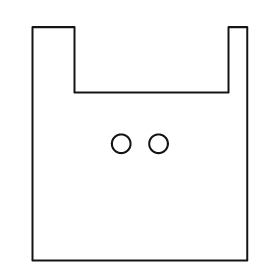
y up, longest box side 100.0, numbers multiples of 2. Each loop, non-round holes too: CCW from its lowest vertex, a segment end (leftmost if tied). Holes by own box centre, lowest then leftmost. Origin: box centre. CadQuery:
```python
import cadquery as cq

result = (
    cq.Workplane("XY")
    .moveTo(-46.0, -50.0)
    .lineTo(46.0, -50.0)
    .lineTo(46.0, 50.0)
    .lineTo(38.0, 50.0)
    .lineTo(38.0, 22.0)
    .lineTo(-28.0, 22.0)
    .lineTo(-28.0, 50.0)
    .lineTo(-46.0, 50.0)
    .close()
    .moveTo(-8.0, 0.0)
    .circle(4.0)
    .moveTo(8.0, 0.0)
    .circle(4.0)
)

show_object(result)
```